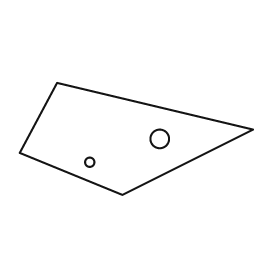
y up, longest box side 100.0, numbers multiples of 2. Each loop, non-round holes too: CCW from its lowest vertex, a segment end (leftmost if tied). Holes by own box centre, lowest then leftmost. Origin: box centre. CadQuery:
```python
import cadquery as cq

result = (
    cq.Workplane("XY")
    .moveTo(-6.0, -24.0)
    .lineTo(50.0, 4.0)
    .lineTo(-34.0, 24.0)
    .lineTo(-50.0, -6.0)
    .close()
    .moveTo(-20.0, -10.0)
    .circle(2.0)
    .moveTo(10.0, 0.0)
    .circle(4.0)
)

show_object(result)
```